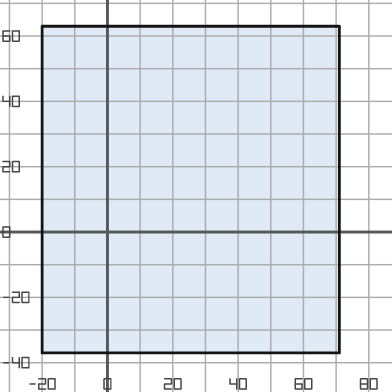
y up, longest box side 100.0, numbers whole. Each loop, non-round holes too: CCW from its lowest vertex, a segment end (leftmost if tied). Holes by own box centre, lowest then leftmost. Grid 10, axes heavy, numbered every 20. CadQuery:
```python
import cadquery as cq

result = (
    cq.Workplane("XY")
    .moveTo(-20.0, -37.0)
    .lineTo(71.0, -37.0)
    .lineTo(71.0, 63.0)
    .lineTo(-20.0, 63.0)
    .close()
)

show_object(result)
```